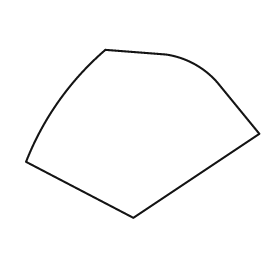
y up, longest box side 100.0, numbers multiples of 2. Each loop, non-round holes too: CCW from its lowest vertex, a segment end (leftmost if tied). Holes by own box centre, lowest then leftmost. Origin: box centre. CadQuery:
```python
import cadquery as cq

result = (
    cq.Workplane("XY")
    .moveTo(-4.0, -36.0)
    .lineTo(50.0, 0.0)
    .lineTo(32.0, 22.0)
    .threePointArc((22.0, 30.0), (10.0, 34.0))
    .lineTo(-16.0, 36.0)
    .threePointArc((-36.0, 14.0), (-50.0, -12.0))
    .close()
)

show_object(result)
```